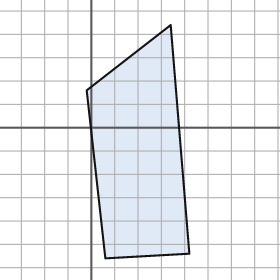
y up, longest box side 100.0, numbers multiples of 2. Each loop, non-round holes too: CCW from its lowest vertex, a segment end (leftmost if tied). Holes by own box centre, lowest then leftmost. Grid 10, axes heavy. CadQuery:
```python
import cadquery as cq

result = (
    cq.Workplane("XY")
    .moveTo(6.0, -56.0)
    .lineTo(42.0, -54.0)
    .lineTo(34.0, 44.0)
    .lineTo(-2.0, 16.0)
    .close()
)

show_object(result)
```